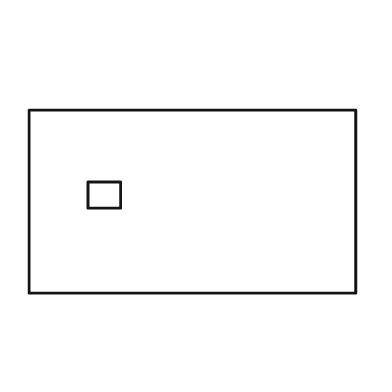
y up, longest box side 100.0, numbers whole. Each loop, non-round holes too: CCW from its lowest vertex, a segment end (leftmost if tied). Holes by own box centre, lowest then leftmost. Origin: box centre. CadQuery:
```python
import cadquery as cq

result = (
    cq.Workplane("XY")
    .moveTo(-50.0, -28.0)
    .lineTo(50.0, -28.0)
    .lineTo(50.0, 28.0)
    .lineTo(-50.0, 28.0)
    .close()
    .moveTo(-32.0, -2.0)
    .lineTo(-22.0, -2.0)
    .lineTo(-22.0, 6.0)
    .lineTo(-32.0, 6.0)
    .close()
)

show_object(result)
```